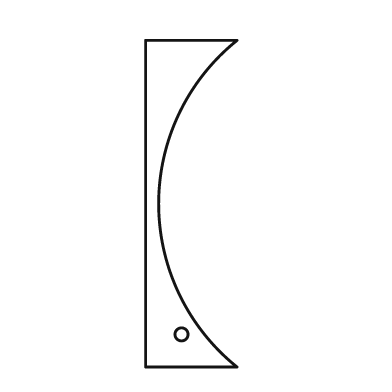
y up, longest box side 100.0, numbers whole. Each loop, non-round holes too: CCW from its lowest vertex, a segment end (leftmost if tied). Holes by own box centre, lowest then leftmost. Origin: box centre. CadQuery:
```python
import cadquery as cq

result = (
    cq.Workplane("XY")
    .moveTo(-14.0, -50.0)
    .lineTo(14.0, -50.0)
    .threePointArc((-10.0, 0.0), (14.0, 50.0))
    .lineTo(-14.0, 50.0)
    .close()
    .moveTo(-3.0, -40.0)
    .circle(2.0)
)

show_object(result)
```